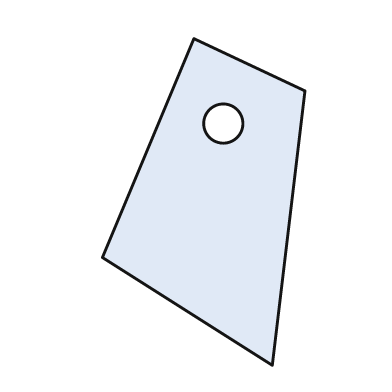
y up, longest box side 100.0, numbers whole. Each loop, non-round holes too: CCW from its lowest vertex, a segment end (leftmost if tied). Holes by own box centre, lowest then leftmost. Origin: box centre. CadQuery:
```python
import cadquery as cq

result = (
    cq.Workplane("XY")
    .moveTo(21.0, -50.0)
    .lineTo(31.0, 34.0)
    .lineTo(-3.0, 50.0)
    .lineTo(-31.0, -17.0)
    .close()
    .moveTo(6.0, 24.0)
    .circle(6.0)
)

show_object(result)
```